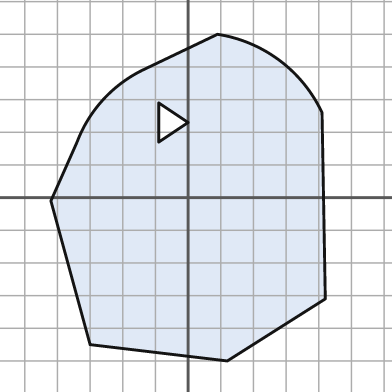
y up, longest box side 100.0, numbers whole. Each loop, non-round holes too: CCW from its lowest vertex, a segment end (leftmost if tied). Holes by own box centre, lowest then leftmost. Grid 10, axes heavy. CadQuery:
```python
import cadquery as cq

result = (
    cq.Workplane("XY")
    .moveTo(12.0, -50.0)
    .lineTo(42.0, -31.0)
    .lineTo(41.0, 26.0)
    .threePointArc((28.0, 42.0), (9.0, 50.0))
    .lineTo(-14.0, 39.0)
    .threePointArc((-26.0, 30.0), (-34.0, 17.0))
    .lineTo(-42.0, -1.0)
    .lineTo(-30.0, -45.0)
    .close()
    .moveTo(-9.0, 17.0)
    .lineTo(0.0, 23.0)
    .lineTo(-9.0, 29.0)
    .close()
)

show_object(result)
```